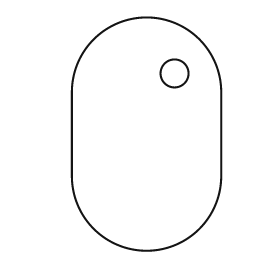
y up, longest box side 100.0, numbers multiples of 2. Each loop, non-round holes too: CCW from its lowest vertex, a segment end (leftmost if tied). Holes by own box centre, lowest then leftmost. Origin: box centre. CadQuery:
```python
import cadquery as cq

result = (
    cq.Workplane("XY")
    .moveTo(-32.0, -18.0)
    .threePointArc((0.0, -50.0), (32.0, -18.0))
    .lineTo(32.0, 18.0)
    .threePointArc((0.0, 50.0), (-32.0, 18.0))
    .close()
    .moveTo(12.0, 26.0)
    .circle(6.0)
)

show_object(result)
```